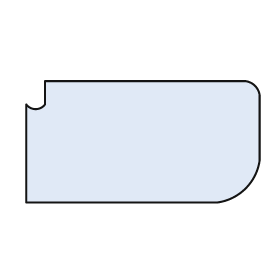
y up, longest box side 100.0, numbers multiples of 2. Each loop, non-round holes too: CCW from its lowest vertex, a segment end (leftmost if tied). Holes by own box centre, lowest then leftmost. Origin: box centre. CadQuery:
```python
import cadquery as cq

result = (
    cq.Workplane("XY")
    .moveTo(-50.0, -26.0)
    .lineTo(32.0, -26.0)
    .threePointArc((44.0, -20.0), (50.0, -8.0))
    .lineTo(50.0, 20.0)
    .threePointArc((48.0, 24.0), (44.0, 26.0))
    .lineTo(-42.0, 26.0)
    .lineTo(-42.0, 16.0)
    .threePointArc((-46.0, 14.0), (-50.0, 16.0))
    .close()
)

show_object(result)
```